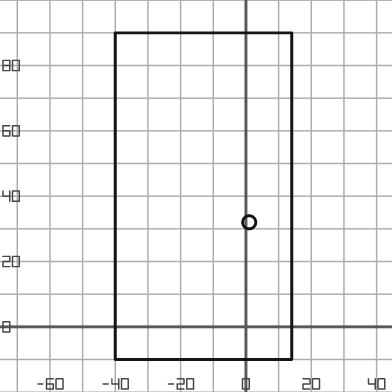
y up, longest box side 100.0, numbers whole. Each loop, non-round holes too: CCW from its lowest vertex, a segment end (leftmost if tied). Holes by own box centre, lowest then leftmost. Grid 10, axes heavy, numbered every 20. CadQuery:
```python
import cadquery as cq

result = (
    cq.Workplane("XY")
    .moveTo(-40.0, -10.0)
    .lineTo(14.0, -10.0)
    .lineTo(14.0, 90.0)
    .lineTo(-40.0, 90.0)
    .close()
    .moveTo(1.0, 32.0)
    .circle(2.0)
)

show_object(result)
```